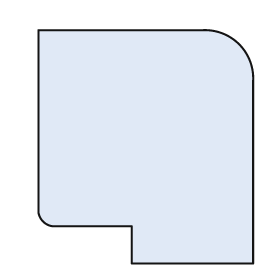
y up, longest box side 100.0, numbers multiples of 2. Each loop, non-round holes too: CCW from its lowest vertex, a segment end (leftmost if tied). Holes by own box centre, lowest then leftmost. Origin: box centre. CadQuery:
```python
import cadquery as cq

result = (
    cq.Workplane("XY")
    .moveTo(-6.0, -50.0)
    .lineTo(46.0, -50.0)
    .lineTo(46.0, 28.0)
    .threePointArc((40.0, 44.0), (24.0, 50.0))
    .lineTo(-46.0, 50.0)
    .lineTo(-46.0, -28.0)
    .threePointArc((-44.0, -32.0), (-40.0, -34.0))
    .lineTo(-6.0, -34.0)
    .close()
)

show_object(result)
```